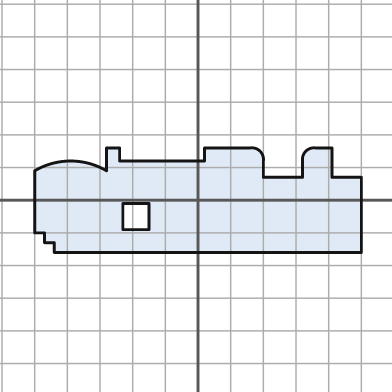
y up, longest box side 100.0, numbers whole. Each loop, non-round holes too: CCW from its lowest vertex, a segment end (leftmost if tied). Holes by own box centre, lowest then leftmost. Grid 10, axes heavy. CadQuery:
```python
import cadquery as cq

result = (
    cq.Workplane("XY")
    .moveTo(-44.0, -16.0)
    .lineTo(50.0, -16.0)
    .lineTo(50.0, 7.0)
    .lineTo(41.0, 7.0)
    .lineTo(41.0, 16.0)
    .lineTo(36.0, 16.0)
    .threePointArc((33.0, 15.0), (32.0, 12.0))
    .lineTo(32.0, 7.0)
    .lineTo(20.0, 7.0)
    .lineTo(20.0, 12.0)
    .threePointArc((19.0, 15.0), (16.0, 16.0))
    .lineTo(2.0, 16.0)
    .lineTo(2.0, 12.0)
    .lineTo(-24.0, 12.0)
    .lineTo(-24.0, 16.0)
    .lineTo(-28.0, 16.0)
    .lineTo(-28.0, 9.0)
    .threePointArc((-39.0, 12.0), (-50.0, 9.0))
    .lineTo(-50.0, -10.0)
    .lineTo(-47.0, -10.0)
    .lineTo(-47.0, -13.0)
    .lineTo(-44.0, -13.0)
    .close()
    .moveTo(-23.0, -9.0)
    .lineTo(-15.0, -9.0)
    .lineTo(-15.0, -1.0)
    .lineTo(-23.0, -1.0)
    .close()
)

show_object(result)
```